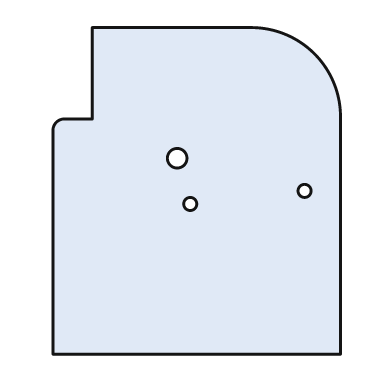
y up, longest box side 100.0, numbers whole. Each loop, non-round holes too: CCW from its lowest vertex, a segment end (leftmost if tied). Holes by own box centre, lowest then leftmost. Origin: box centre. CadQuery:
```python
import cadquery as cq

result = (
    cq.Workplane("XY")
    .moveTo(-44.0, -50.0)
    .lineTo(44.0, -50.0)
    .lineTo(44.0, 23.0)
    .threePointArc((36.0, 42.0), (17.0, 50.0))
    .lineTo(-32.0, 50.0)
    .lineTo(-32.0, 22.0)
    .lineTo(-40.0, 22.0)
    .threePointArc((-43.0, 21.0), (-44.0, 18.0))
    .close()
    .moveTo(-2.0, -4.0)
    .circle(2.0)
    .moveTo(33.0, 0.0)
    .circle(2.0)
    .moveTo(-6.0, 10.0)
    .circle(3.0)
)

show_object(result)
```